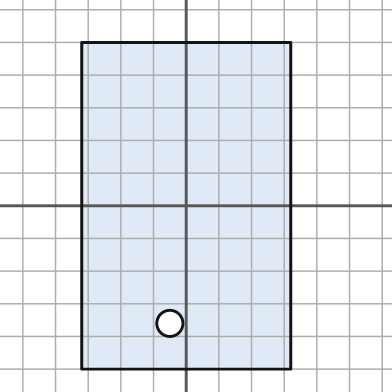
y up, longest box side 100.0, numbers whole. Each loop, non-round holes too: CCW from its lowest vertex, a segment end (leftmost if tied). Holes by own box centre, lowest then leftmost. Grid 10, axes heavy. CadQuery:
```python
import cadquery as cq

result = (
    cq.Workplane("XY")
    .moveTo(-32.0, -50.0)
    .lineTo(32.0, -50.0)
    .lineTo(32.0, 50.0)
    .lineTo(-32.0, 50.0)
    .close()
    .moveTo(-5.0, -36.0)
    .circle(4.0)
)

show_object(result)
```